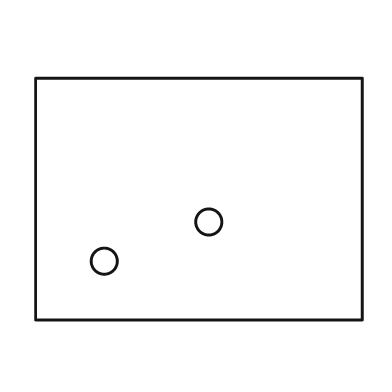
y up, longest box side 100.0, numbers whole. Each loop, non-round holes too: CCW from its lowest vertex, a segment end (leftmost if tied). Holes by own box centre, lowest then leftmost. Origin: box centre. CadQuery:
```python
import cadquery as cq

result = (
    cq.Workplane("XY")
    .moveTo(-50.0, -37.0)
    .lineTo(50.0, -37.0)
    .lineTo(50.0, 37.0)
    .lineTo(-50.0, 37.0)
    .close()
    .moveTo(-29.0, -19.0)
    .circle(4.0)
    .moveTo(3.0, -7.0)
    .circle(4.0)
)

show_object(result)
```